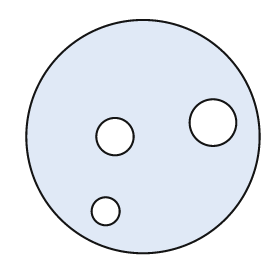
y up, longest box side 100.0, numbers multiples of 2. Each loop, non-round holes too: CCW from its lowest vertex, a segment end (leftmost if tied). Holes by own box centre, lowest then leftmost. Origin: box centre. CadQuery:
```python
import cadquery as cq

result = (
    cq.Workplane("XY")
    .moveTo(0.0, 0.0)
    .circle(50.0)
    .moveTo(-16.0, -32.0)
    .circle(6.0)
    .moveTo(-12.0, 0.0)
    .circle(8.0)
    .moveTo(30.0, 6.0)
    .circle(10.0)
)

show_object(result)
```